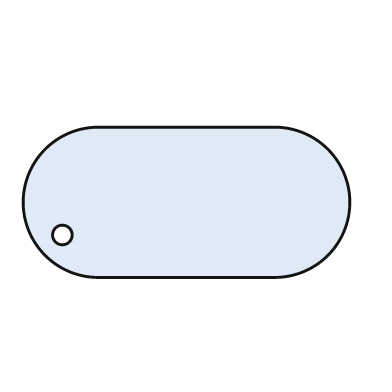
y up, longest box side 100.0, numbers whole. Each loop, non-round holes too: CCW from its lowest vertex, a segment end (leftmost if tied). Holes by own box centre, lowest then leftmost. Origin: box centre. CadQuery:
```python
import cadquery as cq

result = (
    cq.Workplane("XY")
    .moveTo(-27.0, -23.0)
    .lineTo(27.0, -23.0)
    .threePointArc((50.0, 0.0), (27.0, 23.0))
    .lineTo(-27.0, 23.0)
    .threePointArc((-50.0, 0.0), (-27.0, -23.0))
    .close()
    .moveTo(-38.0, -10.0)
    .circle(3.0)
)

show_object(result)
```